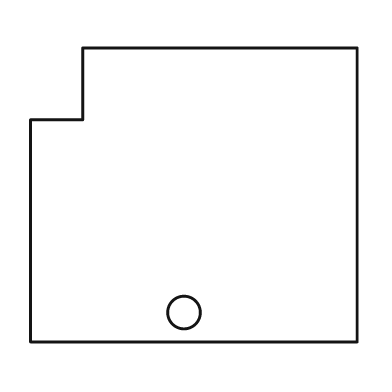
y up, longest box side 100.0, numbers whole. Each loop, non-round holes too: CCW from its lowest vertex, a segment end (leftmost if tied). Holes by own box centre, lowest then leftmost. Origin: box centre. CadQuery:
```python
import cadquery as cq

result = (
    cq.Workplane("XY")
    .moveTo(-50.0, -45.0)
    .lineTo(50.0, -45.0)
    .lineTo(50.0, 45.0)
    .lineTo(-34.0, 45.0)
    .lineTo(-34.0, 23.0)
    .lineTo(-50.0, 23.0)
    .close()
    .moveTo(-3.0, -36.0)
    .circle(5.0)
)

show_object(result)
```